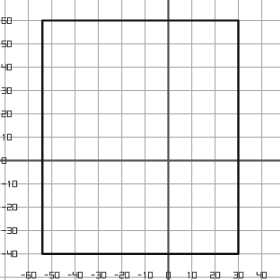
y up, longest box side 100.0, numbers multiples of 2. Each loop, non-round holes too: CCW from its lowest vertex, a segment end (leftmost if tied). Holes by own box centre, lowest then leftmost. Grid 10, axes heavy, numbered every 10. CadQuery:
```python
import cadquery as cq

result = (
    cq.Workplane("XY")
    .moveTo(-54.0, -40.0)
    .lineTo(30.0, -40.0)
    .lineTo(30.0, 60.0)
    .lineTo(-54.0, 60.0)
    .close()
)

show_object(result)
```